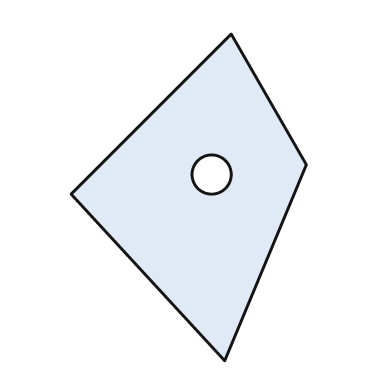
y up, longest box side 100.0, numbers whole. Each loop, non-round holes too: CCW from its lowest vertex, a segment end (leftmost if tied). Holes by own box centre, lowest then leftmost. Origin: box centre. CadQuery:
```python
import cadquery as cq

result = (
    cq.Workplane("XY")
    .moveTo(11.0, -50.0)
    .lineTo(36.0, 10.0)
    .lineTo(13.0, 50.0)
    .lineTo(-36.0, 1.0)
    .close()
    .moveTo(7.0, 7.0)
    .circle(6.0)
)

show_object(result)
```